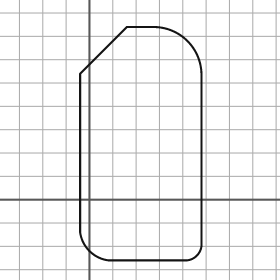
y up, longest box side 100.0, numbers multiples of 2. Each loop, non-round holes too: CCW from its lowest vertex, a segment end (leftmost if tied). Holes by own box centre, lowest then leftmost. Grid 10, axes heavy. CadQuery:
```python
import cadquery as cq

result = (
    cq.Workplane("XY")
    .moveTo(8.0, -26.0)
    .lineTo(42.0, -26.0)
    .threePointArc((46.0, -24.0), (48.0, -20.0))
    .lineTo(48.0, 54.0)
    .threePointArc((42.0, 68.0), (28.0, 74.0))
    .lineTo(16.0, 74.0)
    .lineTo(-4.0, 54.0)
    .lineTo(-4.0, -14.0)
    .threePointArc((0.0, -22.0), (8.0, -26.0))
    .close()
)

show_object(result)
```